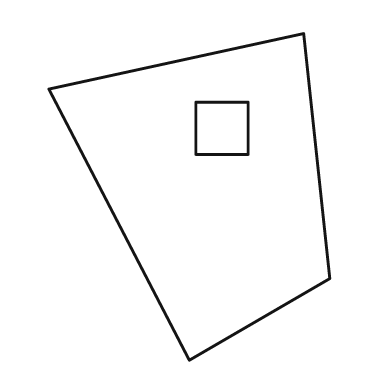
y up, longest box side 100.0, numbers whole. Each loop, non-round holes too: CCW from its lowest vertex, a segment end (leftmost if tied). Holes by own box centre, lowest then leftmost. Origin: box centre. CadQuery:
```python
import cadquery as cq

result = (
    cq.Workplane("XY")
    .moveTo(0.0, -50.0)
    .lineTo(43.0, -25.0)
    .lineTo(35.0, 50.0)
    .lineTo(-43.0, 33.0)
    .close()
    .moveTo(2.0, 13.0)
    .lineTo(18.0, 13.0)
    .lineTo(18.0, 29.0)
    .lineTo(2.0, 29.0)
    .close()
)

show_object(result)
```